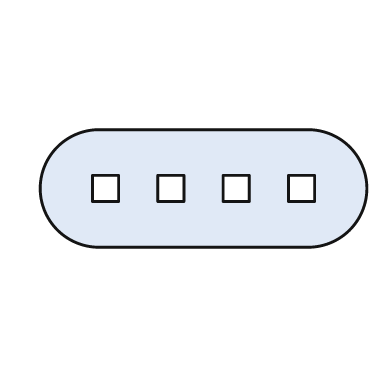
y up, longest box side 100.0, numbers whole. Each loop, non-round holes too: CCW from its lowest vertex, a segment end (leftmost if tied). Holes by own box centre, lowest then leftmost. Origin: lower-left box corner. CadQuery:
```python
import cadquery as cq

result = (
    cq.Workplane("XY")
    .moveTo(18.0, 0.0)
    .lineTo(82.0, 0.0)
    .threePointArc((100.0, 18.0), (82.0, 36.0))
    .lineTo(18.0, 36.0)
    .threePointArc((0.0, 18.0), (18.0, 0.0))
    .close()
    .moveTo(16.0, 14.0)
    .lineTo(24.0, 14.0)
    .lineTo(24.0, 22.0)
    .lineTo(16.0, 22.0)
    .close()
    .moveTo(36.0, 14.0)
    .lineTo(44.0, 14.0)
    .lineTo(44.0, 22.0)
    .lineTo(36.0, 22.0)
    .close()
    .moveTo(56.0, 14.0)
    .lineTo(64.0, 14.0)
    .lineTo(64.0, 22.0)
    .lineTo(56.0, 22.0)
    .close()
    .moveTo(76.0, 14.0)
    .lineTo(84.0, 14.0)
    .lineTo(84.0, 22.0)
    .lineTo(76.0, 22.0)
    .close()
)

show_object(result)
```